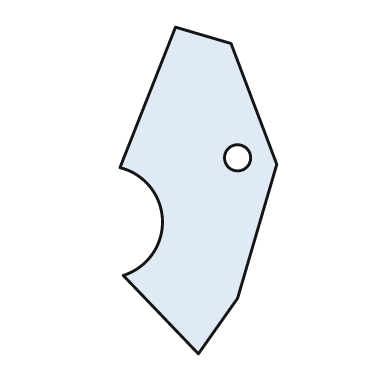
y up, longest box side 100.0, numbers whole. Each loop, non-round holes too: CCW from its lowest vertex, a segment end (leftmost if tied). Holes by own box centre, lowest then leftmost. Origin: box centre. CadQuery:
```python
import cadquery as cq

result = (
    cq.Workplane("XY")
    .moveTo(0.0, -50.0)
    .lineTo(12.0, -33.0)
    .lineTo(24.0, 8.0)
    .lineTo(10.0, 45.0)
    .lineTo(-7.0, 50.0)
    .lineTo(-24.0, 7.0)
    .threePointArc((-11.0, -9.0), (-23.0, -26.0))
    .close()
    .moveTo(12.0, 10.0)
    .circle(4.0)
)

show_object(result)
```